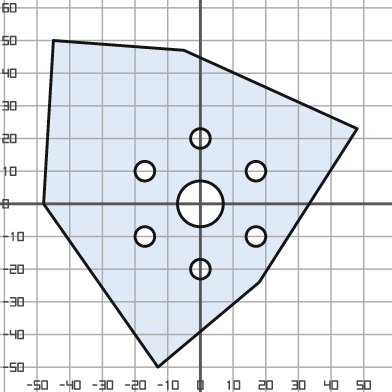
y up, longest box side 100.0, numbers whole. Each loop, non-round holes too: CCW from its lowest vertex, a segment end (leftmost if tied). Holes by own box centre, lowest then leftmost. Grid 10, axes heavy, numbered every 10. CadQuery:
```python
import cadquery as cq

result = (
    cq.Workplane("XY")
    .moveTo(-13.0, -50.0)
    .lineTo(18.0, -24.0)
    .lineTo(48.0, 23.0)
    .lineTo(-5.0, 47.0)
    .lineTo(-45.0, 50.0)
    .lineTo(-48.0, 0.0)
    .close()
    .moveTo(0.0, -20.0)
    .circle(3.0)
    .moveTo(-17.0, -10.0)
    .circle(3.0)
    .moveTo(17.0, -10.0)
    .circle(3.0)
    .moveTo(0.0, 0.0)
    .circle(7.0)
    .moveTo(-17.0, 10.0)
    .circle(3.0)
    .moveTo(17.0, 10.0)
    .circle(3.0)
    .moveTo(0.0, 20.0)
    .circle(3.0)
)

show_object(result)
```